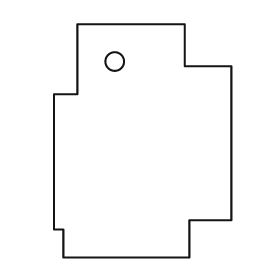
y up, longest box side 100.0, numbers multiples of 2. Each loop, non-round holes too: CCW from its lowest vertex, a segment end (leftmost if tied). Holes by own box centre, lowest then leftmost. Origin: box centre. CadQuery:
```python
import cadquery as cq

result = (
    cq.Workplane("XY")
    .moveTo(-34.0, -50.0)
    .lineTo(20.0, -50.0)
    .lineTo(20.0, -34.0)
    .lineTo(38.0, -34.0)
    .lineTo(38.0, 32.0)
    .lineTo(18.0, 32.0)
    .lineTo(18.0, 50.0)
    .lineTo(-28.0, 50.0)
    .lineTo(-28.0, 20.0)
    .lineTo(-38.0, 20.0)
    .lineTo(-38.0, -38.0)
    .lineTo(-34.0, -38.0)
    .close()
    .moveTo(-12.0, 34.0)
    .circle(4.0)
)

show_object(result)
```